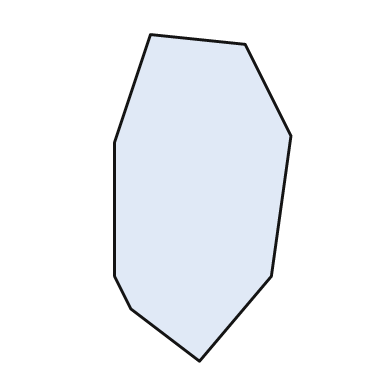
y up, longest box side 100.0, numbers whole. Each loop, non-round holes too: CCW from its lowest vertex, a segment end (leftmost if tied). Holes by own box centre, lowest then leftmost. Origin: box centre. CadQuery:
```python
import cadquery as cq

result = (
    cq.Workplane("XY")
    .moveTo(-1.0, -50.0)
    .lineTo(21.0, -24.0)
    .lineTo(27.0, 19.0)
    .lineTo(13.0, 47.0)
    .lineTo(-16.0, 50.0)
    .lineTo(-27.0, 17.0)
    .lineTo(-27.0, -24.0)
    .lineTo(-22.0, -34.0)
    .close()
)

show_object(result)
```